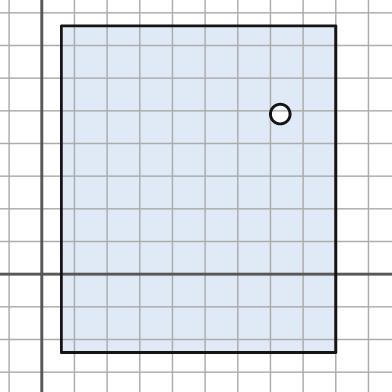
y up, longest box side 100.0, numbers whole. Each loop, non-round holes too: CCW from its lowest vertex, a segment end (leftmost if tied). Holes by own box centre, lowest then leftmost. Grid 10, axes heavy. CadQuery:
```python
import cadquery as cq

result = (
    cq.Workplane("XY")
    .moveTo(6.0, -24.0)
    .lineTo(90.0, -24.0)
    .lineTo(90.0, 76.0)
    .lineTo(6.0, 76.0)
    .close()
    .moveTo(73.0, 49.0)
    .circle(3.0)
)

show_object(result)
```